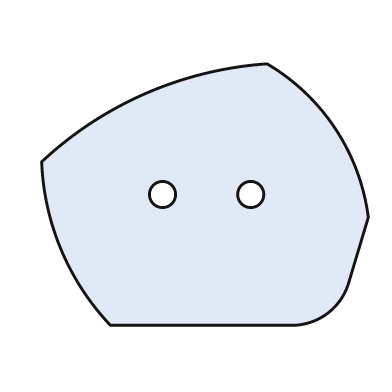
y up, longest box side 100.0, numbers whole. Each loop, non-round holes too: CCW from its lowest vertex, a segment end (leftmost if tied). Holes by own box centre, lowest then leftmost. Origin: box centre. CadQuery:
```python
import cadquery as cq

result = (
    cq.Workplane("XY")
    .moveTo(-29.0, -40.0)
    .lineTo(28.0, -40.0)
    .threePointArc((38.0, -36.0), (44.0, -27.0))
    .lineTo(50.0, -7.0)
    .threePointArc((40.0, 20.0), (19.0, 40.0))
    .threePointArc((-18.0, 31.0), (-50.0, 10.0))
    .threePointArc((-44.0, -17.0), (-29.0, -40.0))
    .close()
    .moveTo(-13.0, 0.0)
    .circle(4.0)
    .moveTo(14.0, 0.0)
    .circle(4.0)
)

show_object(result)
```